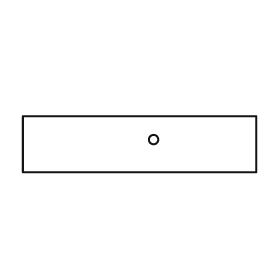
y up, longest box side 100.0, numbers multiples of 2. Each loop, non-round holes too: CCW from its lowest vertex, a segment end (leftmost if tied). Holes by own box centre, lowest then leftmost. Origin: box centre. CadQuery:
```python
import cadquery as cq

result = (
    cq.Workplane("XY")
    .moveTo(-50.0, -12.0)
    .lineTo(50.0, -12.0)
    .lineTo(50.0, 12.0)
    .lineTo(-50.0, 12.0)
    .close()
    .moveTo(6.0, 2.0)
    .circle(2.0)
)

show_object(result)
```